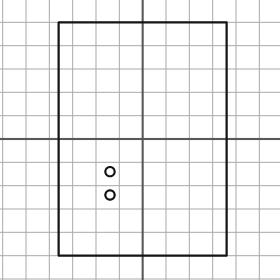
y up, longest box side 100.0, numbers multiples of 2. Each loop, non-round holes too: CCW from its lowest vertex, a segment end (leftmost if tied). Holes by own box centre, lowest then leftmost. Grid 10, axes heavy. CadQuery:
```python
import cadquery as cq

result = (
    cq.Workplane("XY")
    .moveTo(-36.0, -50.0)
    .lineTo(36.0, -50.0)
    .lineTo(36.0, 50.0)
    .lineTo(-36.0, 50.0)
    .close()
    .moveTo(-14.0, -24.0)
    .circle(2.0)
    .moveTo(-14.0, -14.0)
    .circle(2.0)
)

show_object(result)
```